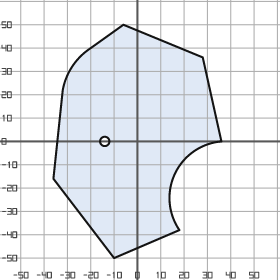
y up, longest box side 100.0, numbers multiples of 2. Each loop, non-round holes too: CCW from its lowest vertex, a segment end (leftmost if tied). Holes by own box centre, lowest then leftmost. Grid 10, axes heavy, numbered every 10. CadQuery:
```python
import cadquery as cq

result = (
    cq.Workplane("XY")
    .moveTo(-10.0, -50.0)
    .lineTo(18.0, -38.0)
    .threePointArc((16.0, -14.0), (36.0, 0.0))
    .lineTo(28.0, 36.0)
    .lineTo(-6.0, 50.0)
    .lineTo(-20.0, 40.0)
    .threePointArc((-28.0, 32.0), (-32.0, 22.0))
    .lineTo(-36.0, -16.0)
    .close()
    .moveTo(-14.0, 0.0)
    .circle(2.0)
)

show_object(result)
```